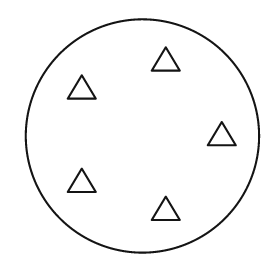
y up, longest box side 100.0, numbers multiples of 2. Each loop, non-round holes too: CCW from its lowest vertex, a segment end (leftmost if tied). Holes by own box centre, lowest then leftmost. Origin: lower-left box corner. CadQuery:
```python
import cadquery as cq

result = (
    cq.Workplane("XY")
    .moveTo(50.0, 50.0)
    .circle(50.0)
    .moveTo(54.0, 14.0)
    .lineTo(66.0, 14.0)
    .lineTo(60.0, 24.0)
    .close()
    .moveTo(18.0, 26.0)
    .lineTo(30.0, 26.0)
    .lineTo(24.0, 36.0)
    .close()
    .moveTo(78.0, 46.0)
    .lineTo(90.0, 46.0)
    .lineTo(84.0, 56.0)
    .close()
    .moveTo(18.0, 66.0)
    .lineTo(30.0, 66.0)
    .lineTo(24.0, 76.0)
    .close()
    .moveTo(54.0, 78.0)
    .lineTo(66.0, 78.0)
    .lineTo(60.0, 88.0)
    .close()
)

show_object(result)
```